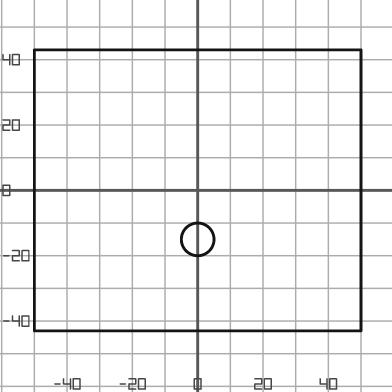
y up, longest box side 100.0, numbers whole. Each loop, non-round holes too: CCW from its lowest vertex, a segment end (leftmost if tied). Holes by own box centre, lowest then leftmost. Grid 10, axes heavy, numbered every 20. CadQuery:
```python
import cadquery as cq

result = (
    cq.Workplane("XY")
    .moveTo(-50.0, -43.0)
    .lineTo(50.0, -43.0)
    .lineTo(50.0, 43.0)
    .lineTo(-50.0, 43.0)
    .close()
    .moveTo(0.0, -15.0)
    .circle(5.0)
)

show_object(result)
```